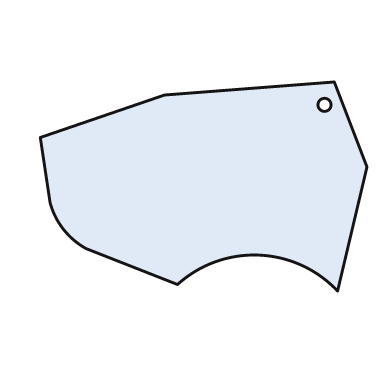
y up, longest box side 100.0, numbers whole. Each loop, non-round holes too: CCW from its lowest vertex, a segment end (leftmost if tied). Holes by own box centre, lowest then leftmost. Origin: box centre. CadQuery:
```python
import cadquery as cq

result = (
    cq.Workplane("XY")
    .moveTo(41.0, -32.0)
    .lineTo(50.0, 6.0)
    .lineTo(40.0, 32.0)
    .lineTo(-12.0, 28.0)
    .lineTo(-50.0, 15.0)
    .lineTo(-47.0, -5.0)
    .threePointArc((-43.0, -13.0), (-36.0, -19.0))
    .lineTo(-8.0, -30.0)
    .threePointArc((17.0, -21.0), (41.0, -32.0))
    .close()
    .moveTo(37.0, 25.0)
    .circle(2.0)
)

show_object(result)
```